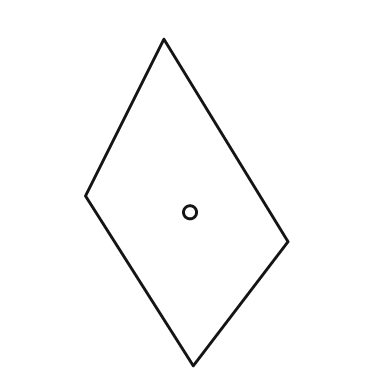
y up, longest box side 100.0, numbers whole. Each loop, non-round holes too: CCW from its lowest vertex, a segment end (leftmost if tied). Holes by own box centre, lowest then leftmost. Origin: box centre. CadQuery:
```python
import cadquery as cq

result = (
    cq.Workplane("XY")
    .moveTo(2.0, -50.0)
    .lineTo(31.0, -12.0)
    .lineTo(-7.0, 50.0)
    .lineTo(-31.0, 2.0)
    .close()
    .moveTo(1.0, -3.0)
    .circle(2.0)
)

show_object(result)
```